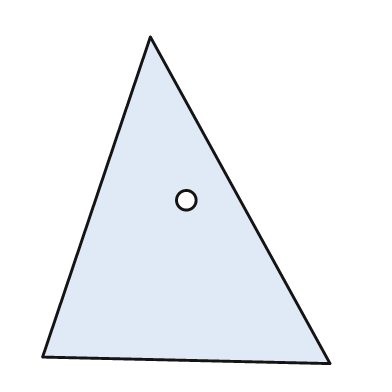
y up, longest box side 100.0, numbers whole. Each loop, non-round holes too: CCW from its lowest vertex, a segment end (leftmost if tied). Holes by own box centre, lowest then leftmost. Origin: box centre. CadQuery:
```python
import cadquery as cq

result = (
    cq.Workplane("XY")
    .moveTo(44.0, -50.0)
    .lineTo(-11.0, 50.0)
    .lineTo(-44.0, -48.0)
    .close()
    .moveTo(0.0, 0.0)
    .circle(3.0)
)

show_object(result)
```